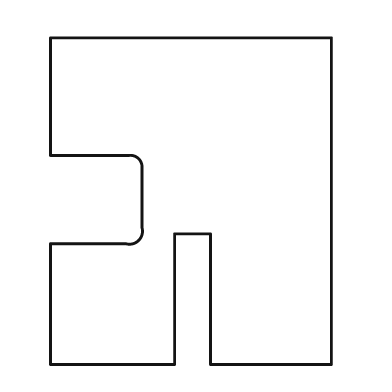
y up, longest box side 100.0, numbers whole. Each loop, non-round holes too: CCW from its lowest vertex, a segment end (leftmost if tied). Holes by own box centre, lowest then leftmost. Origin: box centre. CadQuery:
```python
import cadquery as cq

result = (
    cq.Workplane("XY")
    .moveTo(-43.0, -50.0)
    .lineTo(-5.0, -50.0)
    .lineTo(-5.0, -10.0)
    .lineTo(6.0, -10.0)
    .lineTo(6.0, -50.0)
    .lineTo(43.0, -50.0)
    .lineTo(43.0, 50.0)
    .lineTo(-43.0, 50.0)
    .lineTo(-43.0, 14.0)
    .lineTo(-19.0, 14.0)
    .threePointArc((-16.0, 13.0), (-15.0, 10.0))
    .lineTo(-15.0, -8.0)
    .threePointArc((-16.0, -12.0), (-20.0, -13.0))
    .lineTo(-43.0, -13.0)
    .close()
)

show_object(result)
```